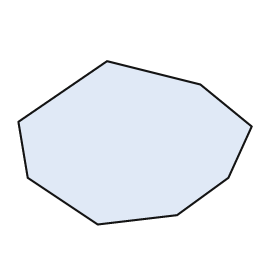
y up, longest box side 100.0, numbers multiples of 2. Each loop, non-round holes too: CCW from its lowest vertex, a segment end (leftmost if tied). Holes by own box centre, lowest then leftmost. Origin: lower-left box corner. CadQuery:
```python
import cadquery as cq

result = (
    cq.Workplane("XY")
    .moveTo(34.0, 0.0)
    .lineTo(68.0, 4.0)
    .lineTo(90.0, 20.0)
    .lineTo(100.0, 42.0)
    .lineTo(78.0, 60.0)
    .lineTo(38.0, 70.0)
    .lineTo(0.0, 44.0)
    .lineTo(4.0, 20.0)
    .close()
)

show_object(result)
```